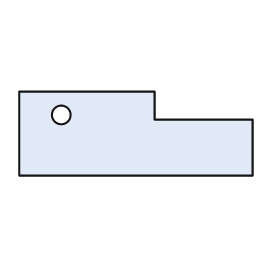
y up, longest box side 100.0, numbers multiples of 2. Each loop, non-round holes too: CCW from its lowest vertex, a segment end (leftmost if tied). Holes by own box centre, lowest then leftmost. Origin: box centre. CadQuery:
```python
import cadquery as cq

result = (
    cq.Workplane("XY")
    .moveTo(-50.0, -18.0)
    .lineTo(50.0, -18.0)
    .lineTo(50.0, 6.0)
    .lineTo(8.0, 6.0)
    .lineTo(8.0, 18.0)
    .lineTo(-50.0, 18.0)
    .close()
    .moveTo(-32.0, 8.0)
    .circle(4.0)
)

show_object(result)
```